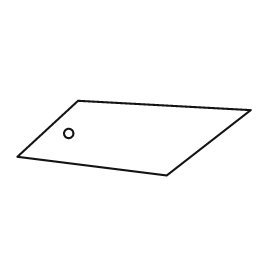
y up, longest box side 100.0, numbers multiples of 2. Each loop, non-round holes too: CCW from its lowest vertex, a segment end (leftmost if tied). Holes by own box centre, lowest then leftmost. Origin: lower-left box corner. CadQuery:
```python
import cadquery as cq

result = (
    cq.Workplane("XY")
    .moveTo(64.0, 0.0)
    .lineTo(100.0, 28.0)
    .lineTo(26.0, 32.0)
    .lineTo(0.0, 8.0)
    .close()
    .moveTo(22.0, 18.0)
    .circle(2.0)
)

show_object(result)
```